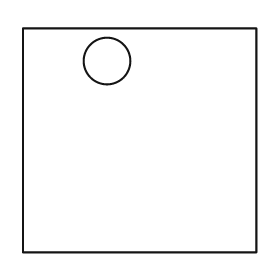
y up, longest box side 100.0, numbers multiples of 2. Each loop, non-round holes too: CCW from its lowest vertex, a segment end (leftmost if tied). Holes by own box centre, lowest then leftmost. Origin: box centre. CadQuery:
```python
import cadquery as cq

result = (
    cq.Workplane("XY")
    .moveTo(-50.0, -48.0)
    .lineTo(50.0, -48.0)
    .lineTo(50.0, 48.0)
    .lineTo(-50.0, 48.0)
    .close()
    .moveTo(-14.0, 34.0)
    .circle(10.0)
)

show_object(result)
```